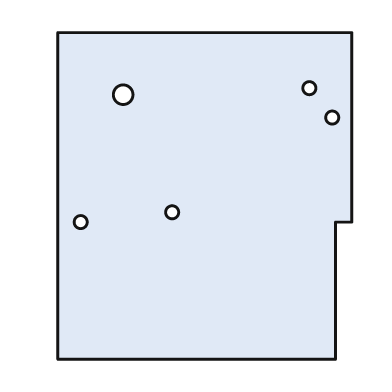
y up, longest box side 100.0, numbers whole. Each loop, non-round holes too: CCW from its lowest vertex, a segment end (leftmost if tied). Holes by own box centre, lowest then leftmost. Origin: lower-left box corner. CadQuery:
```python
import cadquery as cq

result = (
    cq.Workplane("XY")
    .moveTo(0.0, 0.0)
    .lineTo(85.0, 0.0)
    .lineTo(85.0, 42.0)
    .lineTo(90.0, 42.0)
    .lineTo(90.0, 100.0)
    .lineTo(0.0, 100.0)
    .close()
    .moveTo(7.0, 42.0)
    .circle(2.0)
    .moveTo(35.0, 45.0)
    .circle(2.0)
    .moveTo(84.0, 74.0)
    .circle(2.0)
    .moveTo(20.0, 81.0)
    .circle(3.0)
    .moveTo(77.0, 83.0)
    .circle(2.0)
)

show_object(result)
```